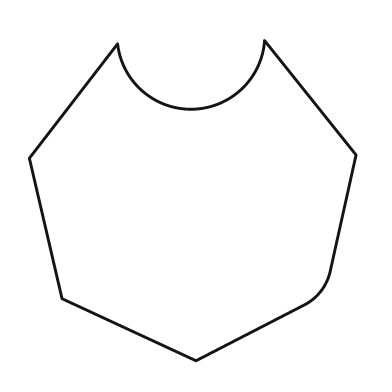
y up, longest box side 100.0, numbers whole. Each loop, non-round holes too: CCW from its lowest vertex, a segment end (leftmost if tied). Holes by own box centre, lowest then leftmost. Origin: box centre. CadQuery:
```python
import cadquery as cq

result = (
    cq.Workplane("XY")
    .moveTo(1.0, -49.0)
    .lineTo(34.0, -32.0)
    .threePointArc((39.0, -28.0), (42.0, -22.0))
    .lineTo(50.0, 14.0)
    .lineTo(22.0, 49.0)
    .threePointArc((0.0, 28.0), (-23.0, 48.0))
    .lineTo(-50.0, 13.0)
    .lineTo(-40.0, -30.0)
    .close()
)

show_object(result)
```